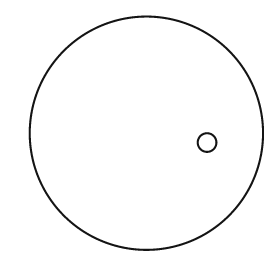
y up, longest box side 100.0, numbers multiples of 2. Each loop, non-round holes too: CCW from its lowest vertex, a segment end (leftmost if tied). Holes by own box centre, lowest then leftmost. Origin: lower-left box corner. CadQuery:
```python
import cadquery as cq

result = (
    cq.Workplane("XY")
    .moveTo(50.0, 50.0)
    .circle(50.0)
    .moveTo(76.0, 46.0)
    .circle(4.0)
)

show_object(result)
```